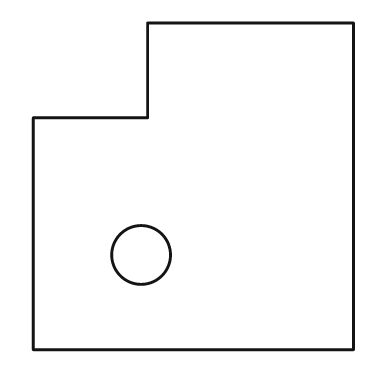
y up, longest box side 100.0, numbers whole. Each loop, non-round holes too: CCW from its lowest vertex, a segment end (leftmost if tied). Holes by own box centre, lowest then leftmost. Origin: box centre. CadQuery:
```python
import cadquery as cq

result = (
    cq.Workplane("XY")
    .moveTo(-49.0, -50.0)
    .lineTo(49.0, -50.0)
    .lineTo(49.0, 50.0)
    .lineTo(-14.0, 50.0)
    .lineTo(-14.0, 21.0)
    .lineTo(-49.0, 21.0)
    .close()
    .moveTo(-16.0, -21.0)
    .circle(9.0)
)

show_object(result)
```